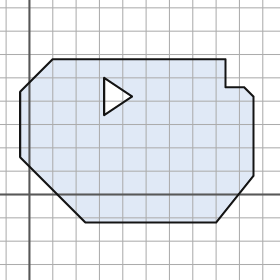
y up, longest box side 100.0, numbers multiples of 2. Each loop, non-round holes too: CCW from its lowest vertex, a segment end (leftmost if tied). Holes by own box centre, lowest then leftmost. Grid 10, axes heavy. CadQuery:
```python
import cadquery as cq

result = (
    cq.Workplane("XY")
    .moveTo(24.0, -12.0)
    .lineTo(80.0, -12.0)
    .lineTo(96.0, 8.0)
    .lineTo(96.0, 42.0)
    .lineTo(92.0, 46.0)
    .lineTo(84.0, 46.0)
    .lineTo(84.0, 58.0)
    .lineTo(10.0, 58.0)
    .lineTo(-4.0, 44.0)
    .lineTo(-4.0, 16.0)
    .close()
    .moveTo(32.0, 34.0)
    .lineTo(44.0, 42.0)
    .lineTo(32.0, 50.0)
    .close()
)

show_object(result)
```